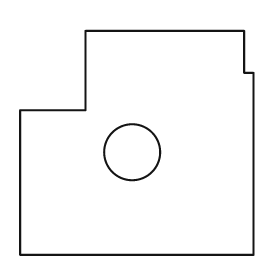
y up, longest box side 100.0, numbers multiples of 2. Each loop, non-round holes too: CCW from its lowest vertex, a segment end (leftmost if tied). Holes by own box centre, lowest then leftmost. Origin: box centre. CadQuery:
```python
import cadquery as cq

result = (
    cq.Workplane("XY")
    .moveTo(-50.0, -48.0)
    .lineTo(50.0, -48.0)
    .lineTo(50.0, 30.0)
    .lineTo(46.0, 30.0)
    .lineTo(46.0, 48.0)
    .lineTo(-22.0, 48.0)
    .lineTo(-22.0, 14.0)
    .lineTo(-50.0, 14.0)
    .close()
    .moveTo(-2.0, -4.0)
    .circle(12.0)
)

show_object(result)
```